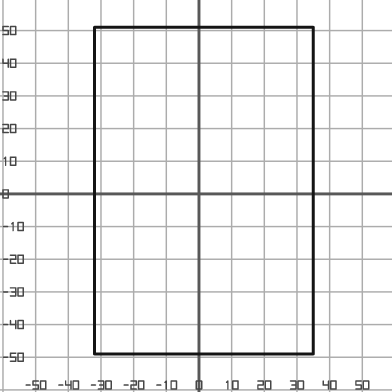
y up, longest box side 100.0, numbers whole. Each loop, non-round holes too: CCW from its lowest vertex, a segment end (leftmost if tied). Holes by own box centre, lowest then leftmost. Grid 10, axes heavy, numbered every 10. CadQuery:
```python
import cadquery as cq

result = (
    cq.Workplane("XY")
    .moveTo(-32.0, -49.0)
    .lineTo(35.0, -49.0)
    .lineTo(35.0, 51.0)
    .lineTo(-32.0, 51.0)
    .close()
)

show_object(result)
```